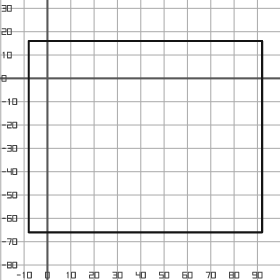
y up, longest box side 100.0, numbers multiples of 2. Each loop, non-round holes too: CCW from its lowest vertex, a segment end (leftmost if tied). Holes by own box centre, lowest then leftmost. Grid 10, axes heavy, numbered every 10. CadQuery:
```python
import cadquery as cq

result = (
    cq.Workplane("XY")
    .moveTo(-8.0, -66.0)
    .lineTo(92.0, -66.0)
    .lineTo(92.0, 16.0)
    .lineTo(-8.0, 16.0)
    .close()
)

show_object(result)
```